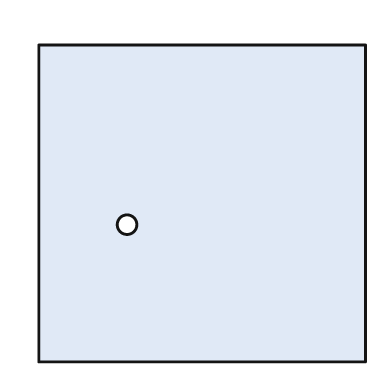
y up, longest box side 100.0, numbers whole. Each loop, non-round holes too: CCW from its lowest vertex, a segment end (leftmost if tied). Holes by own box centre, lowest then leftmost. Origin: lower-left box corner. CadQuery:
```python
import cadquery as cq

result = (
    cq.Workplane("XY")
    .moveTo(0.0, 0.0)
    .lineTo(100.0, 0.0)
    .lineTo(100.0, 97.0)
    .lineTo(0.0, 97.0)
    .close()
    .moveTo(27.0, 42.0)
    .circle(3.0)
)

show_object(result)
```